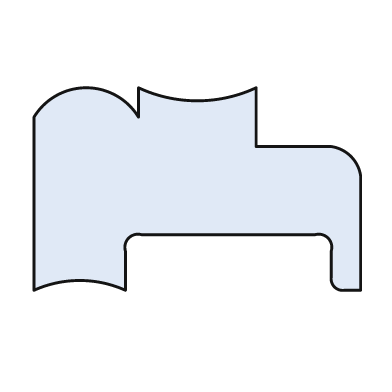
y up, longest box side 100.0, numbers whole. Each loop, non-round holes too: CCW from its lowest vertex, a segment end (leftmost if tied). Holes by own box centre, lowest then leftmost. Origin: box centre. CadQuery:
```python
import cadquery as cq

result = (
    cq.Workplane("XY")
    .moveTo(-50.0, -31.0)
    .threePointArc((-36.0, -28.0), (-22.0, -31.0))
    .lineTo(-22.0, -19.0)
    .threePointArc((-21.0, -15.0), (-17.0, -14.0))
    .lineTo(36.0, -14.0)
    .threePointArc((40.0, -15.0), (41.0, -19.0))
    .lineTo(41.0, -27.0)
    .threePointArc((42.0, -30.0), (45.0, -31.0))
    .lineTo(50.0, -31.0)
    .lineTo(50.0, 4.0)
    .threePointArc((47.0, 10.0), (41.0, 13.0))
    .lineTo(18.0, 13.0)
    .lineTo(18.0, 31.0)
    .threePointArc((0.0, 27.0), (-18.0, 31.0))
    .lineTo(-18.0, 22.0)
    .threePointArc((-34.0, 31.0), (-50.0, 22.0))
    .close()
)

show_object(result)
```